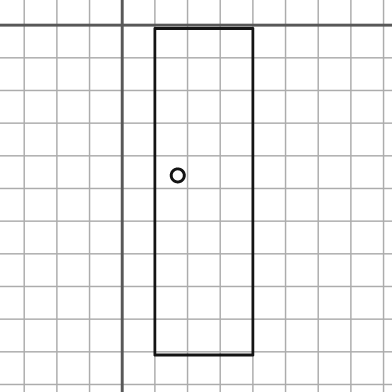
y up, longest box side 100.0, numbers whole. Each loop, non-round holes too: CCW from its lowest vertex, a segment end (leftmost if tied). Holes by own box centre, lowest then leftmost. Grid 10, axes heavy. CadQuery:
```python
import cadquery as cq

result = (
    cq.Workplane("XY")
    .moveTo(10.0, -101.0)
    .lineTo(40.0, -101.0)
    .lineTo(40.0, -1.0)
    .lineTo(10.0, -1.0)
    .close()
    .moveTo(17.0, -46.0)
    .circle(2.0)
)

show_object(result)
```